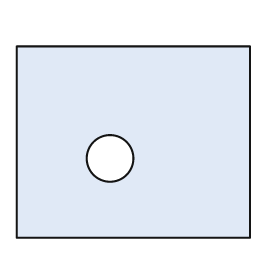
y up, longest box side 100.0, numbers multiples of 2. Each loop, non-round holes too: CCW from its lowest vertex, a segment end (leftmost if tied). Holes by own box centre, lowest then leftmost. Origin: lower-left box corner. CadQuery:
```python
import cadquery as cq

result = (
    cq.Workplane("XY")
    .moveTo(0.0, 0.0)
    .lineTo(100.0, 0.0)
    .lineTo(100.0, 82.0)
    .lineTo(0.0, 82.0)
    .close()
    .moveTo(40.0, 34.0)
    .circle(10.0)
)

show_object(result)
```